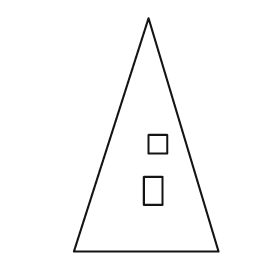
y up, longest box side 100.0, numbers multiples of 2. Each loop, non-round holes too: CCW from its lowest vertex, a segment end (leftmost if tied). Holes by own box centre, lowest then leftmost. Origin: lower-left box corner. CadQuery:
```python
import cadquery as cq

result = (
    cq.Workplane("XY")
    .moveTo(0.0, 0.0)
    .lineTo(62.0, 0.0)
    .lineTo(32.0, 100.0)
    .close()
    .moveTo(30.0, 20.0)
    .lineTo(38.0, 20.0)
    .lineTo(38.0, 32.0)
    .lineTo(30.0, 32.0)
    .close()
    .moveTo(32.0, 42.0)
    .lineTo(40.0, 42.0)
    .lineTo(40.0, 50.0)
    .lineTo(32.0, 50.0)
    .close()
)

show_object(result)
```